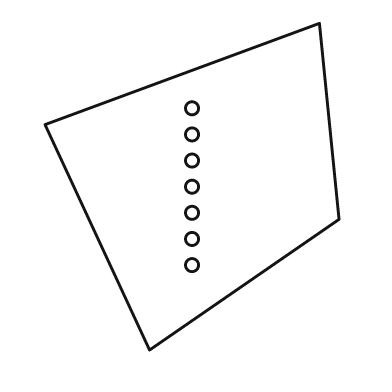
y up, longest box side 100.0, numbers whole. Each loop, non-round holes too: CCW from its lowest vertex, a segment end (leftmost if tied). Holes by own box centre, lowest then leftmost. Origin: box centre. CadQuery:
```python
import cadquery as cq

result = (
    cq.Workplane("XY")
    .moveTo(-13.0, -50.0)
    .lineTo(45.0, -10.0)
    .lineTo(39.0, 50.0)
    .lineTo(-45.0, 19.0)
    .close()
    .moveTo(0.0, -24.0)
    .circle(2.0)
    .moveTo(0.0, -16.0)
    .circle(2.0)
    .moveTo(0.0, -8.0)
    .circle(2.0)
    .moveTo(0.0, 0.0)
    .circle(2.0)
    .moveTo(0.0, 8.0)
    .circle(2.0)
    .moveTo(0.0, 16.0)
    .circle(2.0)
    .moveTo(0.0, 24.0)
    .circle(2.0)
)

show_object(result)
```